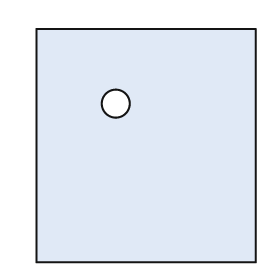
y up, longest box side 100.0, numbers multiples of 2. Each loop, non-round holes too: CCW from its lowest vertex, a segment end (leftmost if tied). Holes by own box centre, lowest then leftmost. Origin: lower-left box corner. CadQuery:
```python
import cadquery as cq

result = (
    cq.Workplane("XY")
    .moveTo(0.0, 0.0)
    .lineTo(94.0, 0.0)
    .lineTo(94.0, 100.0)
    .lineTo(0.0, 100.0)
    .close()
    .moveTo(34.0, 68.0)
    .circle(6.0)
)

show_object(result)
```